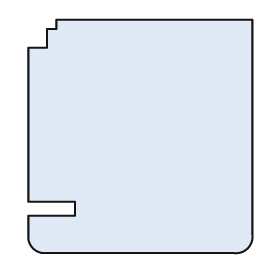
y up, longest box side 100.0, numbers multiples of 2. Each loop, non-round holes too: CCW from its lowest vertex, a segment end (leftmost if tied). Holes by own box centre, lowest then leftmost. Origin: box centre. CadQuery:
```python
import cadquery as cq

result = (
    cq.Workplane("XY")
    .moveTo(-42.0, -50.0)
    .lineTo(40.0, -50.0)
    .threePointArc((46.0, -48.0), (48.0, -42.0))
    .lineTo(48.0, 50.0)
    .lineTo(-36.0, 50.0)
    .lineTo(-36.0, 46.0)
    .lineTo(-40.0, 46.0)
    .lineTo(-40.0, 38.0)
    .lineTo(-48.0, 38.0)
    .lineTo(-48.0, -28.0)
    .lineTo(-28.0, -28.0)
    .lineTo(-28.0, -34.0)
    .lineTo(-48.0, -34.0)
    .lineTo(-48.0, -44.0)
    .threePointArc((-46.0, -48.0), (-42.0, -50.0))
    .close()
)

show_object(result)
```